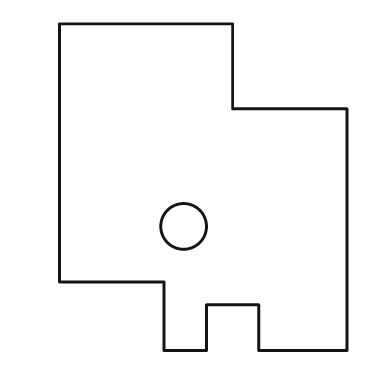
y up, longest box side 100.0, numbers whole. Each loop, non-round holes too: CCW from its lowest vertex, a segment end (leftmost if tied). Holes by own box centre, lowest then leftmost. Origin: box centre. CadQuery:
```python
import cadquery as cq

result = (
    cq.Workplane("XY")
    .moveTo(-12.0, -50.0)
    .lineTo(1.0, -50.0)
    .lineTo(1.0, -36.0)
    .lineTo(17.0, -36.0)
    .lineTo(17.0, -50.0)
    .lineTo(44.0, -50.0)
    .lineTo(44.0, 24.0)
    .lineTo(9.0, 24.0)
    .lineTo(9.0, 50.0)
    .lineTo(-44.0, 50.0)
    .lineTo(-44.0, -29.0)
    .lineTo(-12.0, -29.0)
    .close()
    .moveTo(-6.0, -12.0)
    .circle(7.0)
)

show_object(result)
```